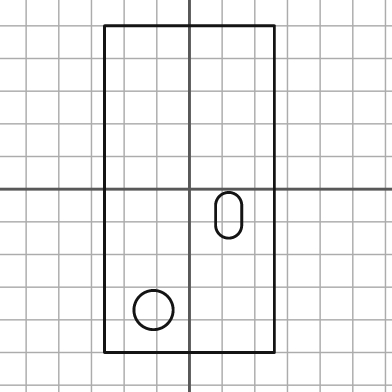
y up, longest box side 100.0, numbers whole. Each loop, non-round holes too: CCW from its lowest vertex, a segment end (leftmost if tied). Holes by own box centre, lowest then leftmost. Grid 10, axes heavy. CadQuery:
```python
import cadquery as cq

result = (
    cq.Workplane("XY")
    .moveTo(-26.0, -50.0)
    .lineTo(26.0, -50.0)
    .lineTo(26.0, 50.0)
    .lineTo(-26.0, 50.0)
    .close()
    .moveTo(-11.0, -37.0)
    .circle(6.0)
    .moveTo(8.0, -11.0)
    .threePointArc((12.0, -15.0), (16.0, -11.0))
    .lineTo(16.0, -5.0)
    .threePointArc((12.0, -1.0), (8.0, -5.0))
    .close()
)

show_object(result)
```